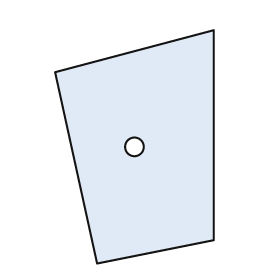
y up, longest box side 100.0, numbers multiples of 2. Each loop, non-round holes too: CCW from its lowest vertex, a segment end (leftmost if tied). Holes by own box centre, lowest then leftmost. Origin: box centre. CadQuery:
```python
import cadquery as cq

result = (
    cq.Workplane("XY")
    .moveTo(-16.0, -50.0)
    .lineTo(34.0, -40.0)
    .lineTo(34.0, 50.0)
    .lineTo(-34.0, 32.0)
    .close()
    .moveTo(0.0, 0.0)
    .circle(4.0)
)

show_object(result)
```